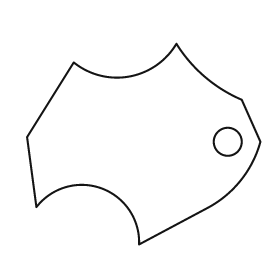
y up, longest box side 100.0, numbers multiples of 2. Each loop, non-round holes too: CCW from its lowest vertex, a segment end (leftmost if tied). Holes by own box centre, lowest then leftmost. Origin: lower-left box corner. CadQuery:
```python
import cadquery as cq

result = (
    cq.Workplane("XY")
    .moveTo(48.0, 0.0)
    .lineTo(78.0, 16.0)
    .threePointArc((92.0, 28.0), (100.0, 44.0))
    .lineTo(92.0, 62.0)
    .threePointArc((76.0, 72.0), (64.0, 86.0))
    .threePointArc((44.0, 72.0), (20.0, 78.0))
    .lineTo(0.0, 46.0)
    .lineTo(4.0, 16.0)
    .threePointArc((32.0, 24.0), (48.0, 0.0))
    .close()
    .moveTo(86.0, 44.0)
    .circle(6.0)
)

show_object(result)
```